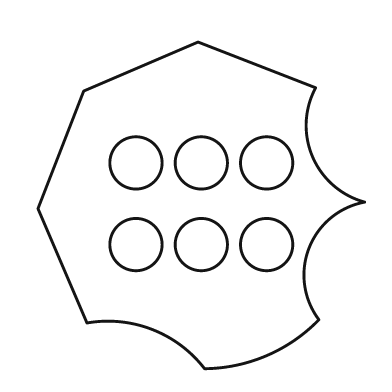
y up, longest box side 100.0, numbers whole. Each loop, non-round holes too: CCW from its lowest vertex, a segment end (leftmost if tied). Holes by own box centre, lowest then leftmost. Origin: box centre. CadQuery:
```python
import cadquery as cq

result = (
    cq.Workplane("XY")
    .moveTo(1.0, -50.0)
    .threePointArc((20.0, -46.0), (36.0, -35.0))
    .threePointArc((33.0, -13.0), (50.0, 1.0))
    .threePointArc((34.0, 15.0), (35.0, 36.0))
    .lineTo(-1.0, 50.0)
    .lineTo(-36.0, 35.0)
    .lineTo(-50.0, -1.0)
    .lineTo(-35.0, -36.0)
    .threePointArc((-15.0, -38.0), (1.0, -50.0))
    .close()
    .moveTo(-20.0, -12.0)
    .circle(8.0)
    .moveTo(0.0, -12.0)
    .circle(8.0)
    .moveTo(20.0, -12.0)
    .circle(8.0)
    .moveTo(-20.0, 13.0)
    .circle(8.0)
    .moveTo(0.0, 13.0)
    .circle(8.0)
    .moveTo(20.0, 13.0)
    .circle(8.0)
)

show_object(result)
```